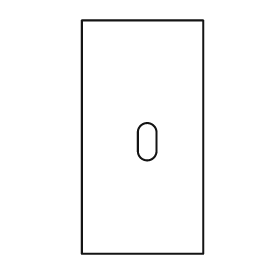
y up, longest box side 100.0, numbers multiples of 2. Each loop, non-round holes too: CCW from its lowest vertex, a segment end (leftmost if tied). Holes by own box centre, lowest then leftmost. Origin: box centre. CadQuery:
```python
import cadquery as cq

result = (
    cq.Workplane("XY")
    .moveTo(-26.0, -50.0)
    .lineTo(26.0, -50.0)
    .lineTo(26.0, 50.0)
    .lineTo(-26.0, 50.0)
    .close()
    .moveTo(-2.0, -6.0)
    .threePointArc((2.0, -10.0), (6.0, -6.0))
    .lineTo(6.0, 2.0)
    .threePointArc((2.0, 6.0), (-2.0, 2.0))
    .close()
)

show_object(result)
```